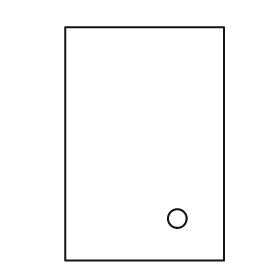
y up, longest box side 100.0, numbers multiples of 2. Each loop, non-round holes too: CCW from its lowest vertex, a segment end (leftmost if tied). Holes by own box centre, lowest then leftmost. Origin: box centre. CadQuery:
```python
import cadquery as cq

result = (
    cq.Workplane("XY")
    .moveTo(-34.0, -50.0)
    .lineTo(34.0, -50.0)
    .lineTo(34.0, 50.0)
    .lineTo(-34.0, 50.0)
    .close()
    .moveTo(14.0, -32.0)
    .circle(4.0)
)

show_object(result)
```